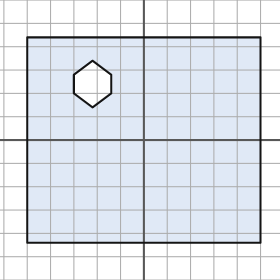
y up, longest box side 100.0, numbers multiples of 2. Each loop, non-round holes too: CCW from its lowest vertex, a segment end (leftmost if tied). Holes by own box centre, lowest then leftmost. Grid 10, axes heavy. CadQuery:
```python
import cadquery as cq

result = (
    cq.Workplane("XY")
    .moveTo(-50.0, -44.0)
    .lineTo(50.0, -44.0)
    .lineTo(50.0, 44.0)
    .lineTo(-50.0, 44.0)
    .close()
    .moveTo(-22.0, 14.0)
    .lineTo(-14.0, 20.0)
    .lineTo(-14.0, 28.0)
    .lineTo(-22.0, 34.0)
    .lineTo(-30.0, 28.0)
    .lineTo(-30.0, 20.0)
    .close()
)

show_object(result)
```